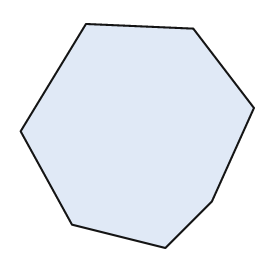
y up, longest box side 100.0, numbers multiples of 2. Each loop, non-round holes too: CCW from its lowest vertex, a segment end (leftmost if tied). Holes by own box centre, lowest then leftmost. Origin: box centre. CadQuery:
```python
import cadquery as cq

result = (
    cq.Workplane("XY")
    .moveTo(12.0, -48.0)
    .lineTo(32.0, -28.0)
    .lineTo(50.0, 12.0)
    .lineTo(24.0, 46.0)
    .lineTo(-22.0, 48.0)
    .lineTo(-50.0, 2.0)
    .lineTo(-28.0, -38.0)
    .close()
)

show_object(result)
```